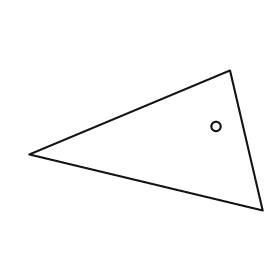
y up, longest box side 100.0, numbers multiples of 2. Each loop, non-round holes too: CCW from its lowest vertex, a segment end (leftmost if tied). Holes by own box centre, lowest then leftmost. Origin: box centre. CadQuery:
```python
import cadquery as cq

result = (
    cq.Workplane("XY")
    .moveTo(50.0, -30.0)
    .lineTo(36.0, 30.0)
    .lineTo(-50.0, -6.0)
    .close()
    .moveTo(30.0, 6.0)
    .circle(2.0)
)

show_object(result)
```